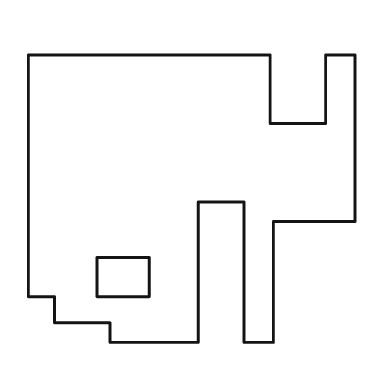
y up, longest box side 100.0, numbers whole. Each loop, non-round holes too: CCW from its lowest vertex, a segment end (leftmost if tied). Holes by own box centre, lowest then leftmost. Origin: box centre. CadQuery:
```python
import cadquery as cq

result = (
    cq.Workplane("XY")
    .moveTo(-25.0, -44.0)
    .lineTo(2.0, -44.0)
    .lineTo(2.0, -1.0)
    .lineTo(16.0, -1.0)
    .lineTo(16.0, -44.0)
    .lineTo(25.0, -44.0)
    .lineTo(25.0, -7.0)
    .lineTo(50.0, -7.0)
    .lineTo(50.0, 44.0)
    .lineTo(41.0, 44.0)
    .lineTo(41.0, 23.0)
    .lineTo(24.0, 23.0)
    .lineTo(24.0, 44.0)
    .lineTo(-50.0, 44.0)
    .lineTo(-50.0, -30.0)
    .lineTo(-42.0, -30.0)
    .lineTo(-42.0, -38.0)
    .lineTo(-25.0, -38.0)
    .close()
    .moveTo(-29.0, -30.0)
    .lineTo(-13.0, -30.0)
    .lineTo(-13.0, -18.0)
    .lineTo(-29.0, -18.0)
    .close()
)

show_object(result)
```